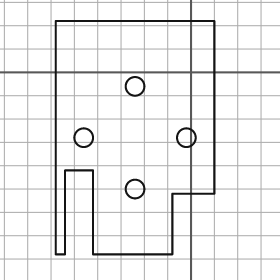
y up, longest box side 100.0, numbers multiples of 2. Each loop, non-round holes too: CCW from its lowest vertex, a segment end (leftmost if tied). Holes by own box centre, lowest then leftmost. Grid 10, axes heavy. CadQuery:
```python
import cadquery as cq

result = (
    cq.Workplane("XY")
    .moveTo(-58.0, -78.0)
    .lineTo(-54.0, -78.0)
    .lineTo(-54.0, -42.0)
    .lineTo(-42.0, -42.0)
    .lineTo(-42.0, -78.0)
    .lineTo(-8.0, -78.0)
    .lineTo(-8.0, -52.0)
    .lineTo(10.0, -52.0)
    .lineTo(10.0, 22.0)
    .lineTo(-58.0, 22.0)
    .close()
    .moveTo(-24.0, -50.0)
    .circle(4.0)
    .moveTo(-46.0, -28.0)
    .circle(4.0)
    .moveTo(-2.0, -28.0)
    .circle(4.0)
    .moveTo(-24.0, -6.0)
    .circle(4.0)
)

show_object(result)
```